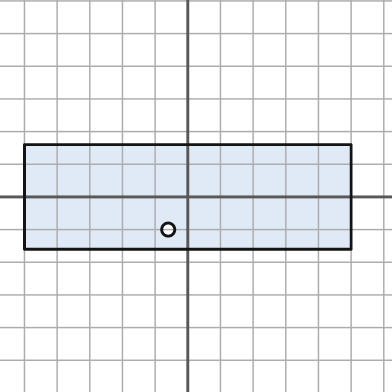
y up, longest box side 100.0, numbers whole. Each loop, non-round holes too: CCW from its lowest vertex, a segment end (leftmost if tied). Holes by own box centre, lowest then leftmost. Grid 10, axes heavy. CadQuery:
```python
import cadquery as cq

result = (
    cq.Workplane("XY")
    .moveTo(-50.0, -16.0)
    .lineTo(50.0, -16.0)
    .lineTo(50.0, 16.0)
    .lineTo(-50.0, 16.0)
    .close()
    .moveTo(-6.0, -10.0)
    .circle(2.0)
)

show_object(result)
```